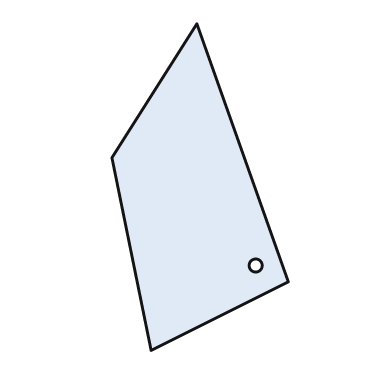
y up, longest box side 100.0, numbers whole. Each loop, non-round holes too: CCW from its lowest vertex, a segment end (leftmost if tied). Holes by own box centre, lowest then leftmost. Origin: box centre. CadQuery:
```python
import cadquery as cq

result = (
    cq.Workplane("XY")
    .moveTo(-15.0, -50.0)
    .lineTo(27.0, -29.0)
    .lineTo(-1.0, 50.0)
    .lineTo(-27.0, 9.0)
    .close()
    .moveTo(17.0, -24.0)
    .circle(2.0)
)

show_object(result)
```